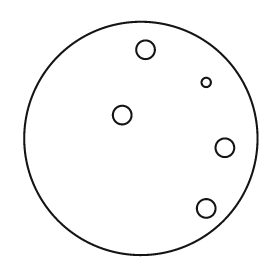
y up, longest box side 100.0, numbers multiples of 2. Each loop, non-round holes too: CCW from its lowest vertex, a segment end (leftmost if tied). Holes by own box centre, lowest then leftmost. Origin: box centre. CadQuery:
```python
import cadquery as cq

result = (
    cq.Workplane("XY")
    .moveTo(0.0, 0.0)
    .circle(50.0)
    .moveTo(28.0, -30.0)
    .circle(4.0)
    .moveTo(36.0, -4.0)
    .circle(4.0)
    .moveTo(-8.0, 10.0)
    .circle(4.0)
    .moveTo(28.0, 24.0)
    .circle(2.0)
    .moveTo(2.0, 38.0)
    .circle(4.0)
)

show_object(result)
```